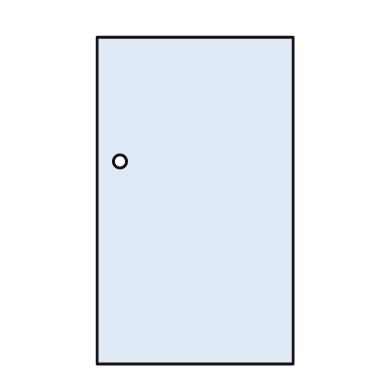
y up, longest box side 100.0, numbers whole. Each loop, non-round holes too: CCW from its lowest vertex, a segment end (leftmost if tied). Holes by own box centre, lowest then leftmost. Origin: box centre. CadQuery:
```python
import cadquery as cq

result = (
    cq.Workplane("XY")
    .moveTo(-30.0, -50.0)
    .lineTo(30.0, -50.0)
    .lineTo(30.0, 50.0)
    .lineTo(-30.0, 50.0)
    .close()
    .moveTo(-23.0, 12.0)
    .circle(2.0)
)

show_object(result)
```